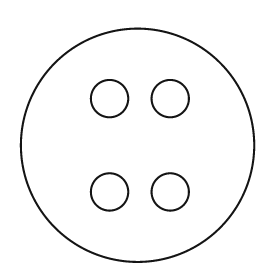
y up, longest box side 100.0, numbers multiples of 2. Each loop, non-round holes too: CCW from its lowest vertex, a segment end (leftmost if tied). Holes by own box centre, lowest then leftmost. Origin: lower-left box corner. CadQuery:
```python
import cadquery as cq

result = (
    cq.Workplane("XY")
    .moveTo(50.0, 50.0)
    .circle(50.0)
    .moveTo(38.0, 30.0)
    .circle(8.0)
    .moveTo(64.0, 30.0)
    .circle(8.0)
    .moveTo(38.0, 70.0)
    .circle(8.0)
    .moveTo(64.0, 70.0)
    .circle(8.0)
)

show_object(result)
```